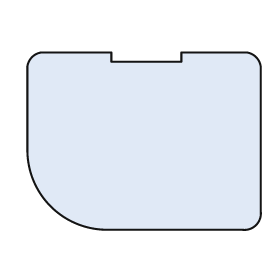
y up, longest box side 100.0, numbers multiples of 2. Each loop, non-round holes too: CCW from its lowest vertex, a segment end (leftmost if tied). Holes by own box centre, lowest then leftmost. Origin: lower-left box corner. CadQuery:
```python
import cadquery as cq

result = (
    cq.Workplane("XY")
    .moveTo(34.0, 0.0)
    .lineTo(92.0, 0.0)
    .threePointArc((98.0, 2.0), (100.0, 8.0))
    .lineTo(100.0, 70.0)
    .threePointArc((98.0, 74.0), (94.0, 76.0))
    .lineTo(66.0, 76.0)
    .lineTo(66.0, 72.0)
    .lineTo(36.0, 72.0)
    .lineTo(36.0, 76.0)
    .lineTo(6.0, 76.0)
    .threePointArc((2.0, 74.0), (0.0, 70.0))
    .lineTo(0.0, 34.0)
    .threePointArc((10.0, 10.0), (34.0, 0.0))
    .close()
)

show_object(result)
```